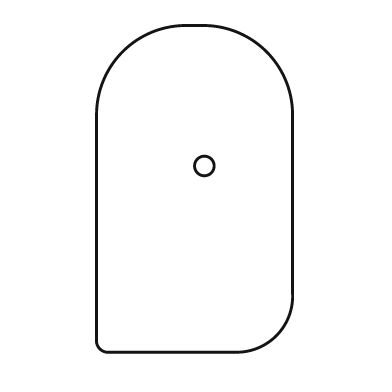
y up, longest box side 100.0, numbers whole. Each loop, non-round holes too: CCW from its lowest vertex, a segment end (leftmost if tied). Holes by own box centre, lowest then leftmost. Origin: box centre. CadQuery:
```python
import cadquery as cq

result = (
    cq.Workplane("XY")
    .moveTo(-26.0, -50.0)
    .lineTo(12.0, -50.0)
    .threePointArc((25.0, -45.0), (30.0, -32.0))
    .lineTo(30.0, 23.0)
    .threePointArc((22.0, 42.0), (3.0, 50.0))
    .lineTo(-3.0, 50.0)
    .threePointArc((-22.0, 42.0), (-30.0, 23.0))
    .lineTo(-30.0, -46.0)
    .threePointArc((-29.0, -49.0), (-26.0, -50.0))
    .close()
    .moveTo(3.0, 7.0)
    .circle(3.0)
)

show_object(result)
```